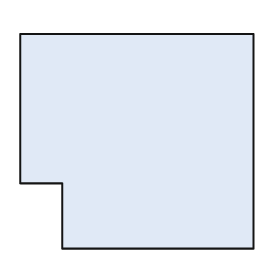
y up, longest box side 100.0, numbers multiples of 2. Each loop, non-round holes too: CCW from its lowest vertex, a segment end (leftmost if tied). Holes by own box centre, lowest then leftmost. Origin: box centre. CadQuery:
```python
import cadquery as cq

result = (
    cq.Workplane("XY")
    .moveTo(-32.0, -46.0)
    .lineTo(50.0, -46.0)
    .lineTo(50.0, 46.0)
    .lineTo(-50.0, 46.0)
    .lineTo(-50.0, -18.0)
    .lineTo(-32.0, -18.0)
    .close()
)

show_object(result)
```